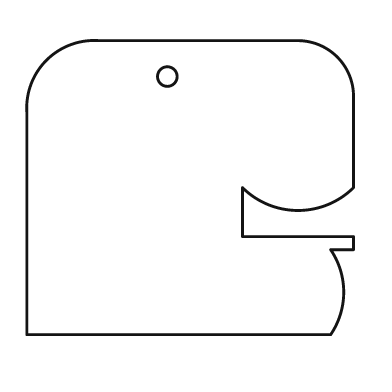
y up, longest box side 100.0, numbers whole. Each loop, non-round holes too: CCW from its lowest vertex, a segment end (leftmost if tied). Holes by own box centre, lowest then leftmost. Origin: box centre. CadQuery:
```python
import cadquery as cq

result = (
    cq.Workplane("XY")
    .moveTo(-50.0, -45.0)
    .lineTo(43.0, -45.0)
    .threePointArc((47.0, -32.0), (43.0, -19.0))
    .lineTo(50.0, -19.0)
    .lineTo(50.0, -15.0)
    .lineTo(16.0, -15.0)
    .lineTo(16.0, 0.0)
    .threePointArc((33.0, -7.0), (50.0, 0.0))
    .lineTo(50.0, 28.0)
    .threePointArc((45.0, 40.0), (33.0, 45.0))
    .lineTo(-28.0, 45.0)
    .threePointArc((-44.0, 39.0), (-50.0, 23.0))
    .close()
    .moveTo(-7.0, 34.0)
    .circle(3.0)
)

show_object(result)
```